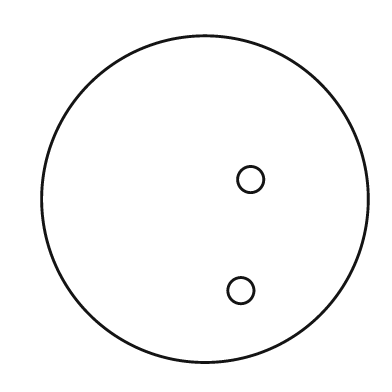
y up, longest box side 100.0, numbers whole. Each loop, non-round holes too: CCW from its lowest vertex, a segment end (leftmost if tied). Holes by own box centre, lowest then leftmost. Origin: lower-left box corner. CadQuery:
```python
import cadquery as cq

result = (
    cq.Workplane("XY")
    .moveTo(50.0, 50.0)
    .circle(50.0)
    .moveTo(61.0, 22.0)
    .circle(4.0)
    .moveTo(64.0, 56.0)
    .circle(4.0)
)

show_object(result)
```